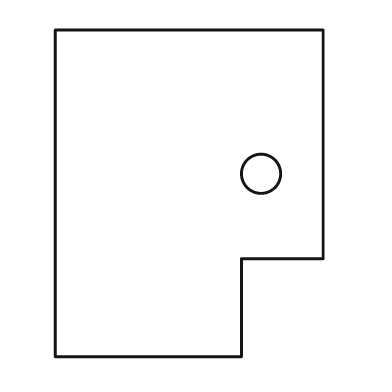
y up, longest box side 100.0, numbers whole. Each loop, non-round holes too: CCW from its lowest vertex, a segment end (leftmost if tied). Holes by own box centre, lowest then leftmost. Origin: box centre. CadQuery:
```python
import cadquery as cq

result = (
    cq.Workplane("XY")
    .moveTo(-41.0, -50.0)
    .lineTo(16.0, -50.0)
    .lineTo(16.0, -20.0)
    .lineTo(41.0, -20.0)
    .lineTo(41.0, 50.0)
    .lineTo(-41.0, 50.0)
    .close()
    .moveTo(22.0, 6.0)
    .circle(6.0)
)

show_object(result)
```